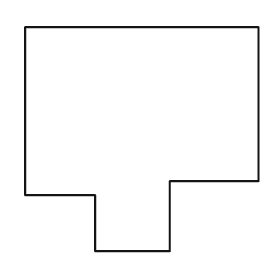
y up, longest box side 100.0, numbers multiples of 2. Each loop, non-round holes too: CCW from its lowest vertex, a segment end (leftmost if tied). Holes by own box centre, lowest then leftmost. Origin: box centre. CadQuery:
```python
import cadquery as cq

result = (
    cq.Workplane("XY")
    .moveTo(-20.0, -48.0)
    .lineTo(12.0, -48.0)
    .lineTo(12.0, -18.0)
    .lineTo(50.0, -18.0)
    .lineTo(50.0, 48.0)
    .lineTo(-50.0, 48.0)
    .lineTo(-50.0, -24.0)
    .lineTo(-20.0, -24.0)
    .close()
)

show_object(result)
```